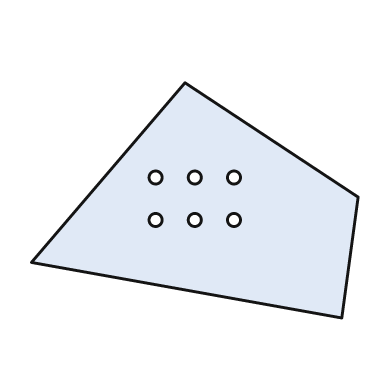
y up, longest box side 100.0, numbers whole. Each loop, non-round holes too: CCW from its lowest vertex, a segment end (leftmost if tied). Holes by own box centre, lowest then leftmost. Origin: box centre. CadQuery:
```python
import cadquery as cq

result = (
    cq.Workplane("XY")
    .moveTo(45.0, -36.0)
    .lineTo(50.0, 1.0)
    .lineTo(-3.0, 36.0)
    .lineTo(-50.0, -19.0)
    .close()
    .moveTo(-12.0, -6.0)
    .circle(2.0)
    .moveTo(0.0, -6.0)
    .circle(2.0)
    .moveTo(12.0, -6.0)
    .circle(2.0)
    .moveTo(-12.0, 7.0)
    .circle(2.0)
    .moveTo(0.0, 7.0)
    .circle(2.0)
    .moveTo(12.0, 7.0)
    .circle(2.0)
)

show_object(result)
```